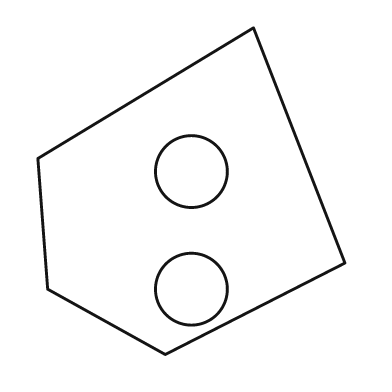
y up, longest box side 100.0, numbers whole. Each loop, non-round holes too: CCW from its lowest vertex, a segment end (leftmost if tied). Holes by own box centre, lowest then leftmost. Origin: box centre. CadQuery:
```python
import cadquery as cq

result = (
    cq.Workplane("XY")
    .moveTo(-8.0, -50.0)
    .lineTo(47.0, -22.0)
    .lineTo(19.0, 50.0)
    .lineTo(-47.0, 10.0)
    .lineTo(-44.0, -30.0)
    .close()
    .moveTo(0.0, -30.0)
    .circle(11.0)
    .moveTo(0.0, 6.0)
    .circle(11.0)
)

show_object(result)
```